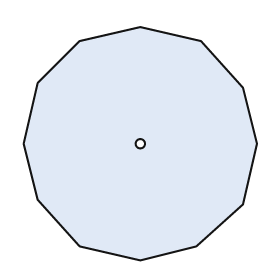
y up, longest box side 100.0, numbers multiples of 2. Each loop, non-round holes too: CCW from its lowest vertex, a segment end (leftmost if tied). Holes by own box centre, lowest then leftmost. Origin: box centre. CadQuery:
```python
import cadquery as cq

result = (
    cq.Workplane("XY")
    .moveTo(0.0, -50.0)
    .lineTo(24.0, -44.0)
    .lineTo(44.0, -26.0)
    .lineTo(50.0, 0.0)
    .lineTo(44.0, 24.0)
    .lineTo(26.0, 44.0)
    .lineTo(0.0, 50.0)
    .lineTo(-26.0, 44.0)
    .lineTo(-44.0, 26.0)
    .lineTo(-50.0, 0.0)
    .lineTo(-44.0, -24.0)
    .lineTo(-26.0, -44.0)
    .close()
    .moveTo(0.0, 0.0)
    .circle(2.0)
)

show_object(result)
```